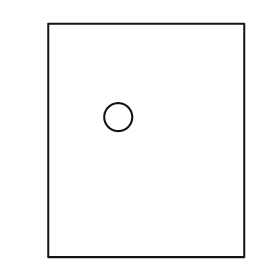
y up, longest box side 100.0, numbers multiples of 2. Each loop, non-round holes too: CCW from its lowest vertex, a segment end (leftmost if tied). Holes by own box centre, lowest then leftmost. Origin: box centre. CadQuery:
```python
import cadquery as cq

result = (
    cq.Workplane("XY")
    .moveTo(-42.0, -50.0)
    .lineTo(42.0, -50.0)
    .lineTo(42.0, 50.0)
    .lineTo(-42.0, 50.0)
    .close()
    .moveTo(-12.0, 10.0)
    .circle(6.0)
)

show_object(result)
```